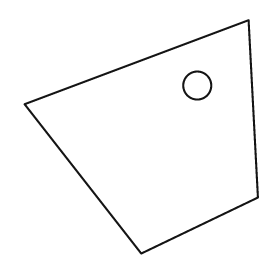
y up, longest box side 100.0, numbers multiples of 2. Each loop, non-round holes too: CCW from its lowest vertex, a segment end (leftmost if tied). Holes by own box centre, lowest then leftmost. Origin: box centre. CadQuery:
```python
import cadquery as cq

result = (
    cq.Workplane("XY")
    .moveTo(0.0, -50.0)
    .lineTo(50.0, -26.0)
    .lineTo(46.0, 50.0)
    .lineTo(-50.0, 14.0)
    .close()
    .moveTo(24.0, 22.0)
    .circle(6.0)
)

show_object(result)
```